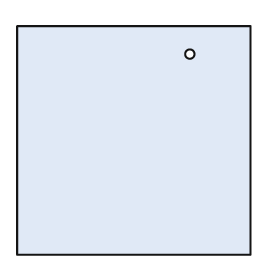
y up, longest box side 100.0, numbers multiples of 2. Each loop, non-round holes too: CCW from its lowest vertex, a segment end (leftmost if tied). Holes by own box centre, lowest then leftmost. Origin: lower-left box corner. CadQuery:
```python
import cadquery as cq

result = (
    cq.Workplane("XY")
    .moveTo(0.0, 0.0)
    .lineTo(100.0, 0.0)
    .lineTo(100.0, 98.0)
    .lineTo(0.0, 98.0)
    .close()
    .moveTo(74.0, 86.0)
    .circle(2.0)
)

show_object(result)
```